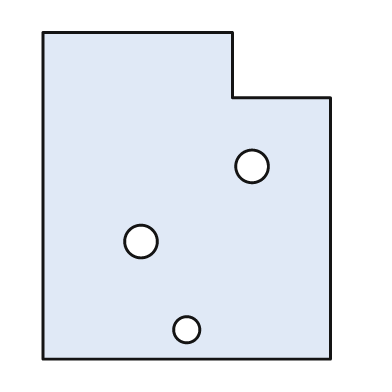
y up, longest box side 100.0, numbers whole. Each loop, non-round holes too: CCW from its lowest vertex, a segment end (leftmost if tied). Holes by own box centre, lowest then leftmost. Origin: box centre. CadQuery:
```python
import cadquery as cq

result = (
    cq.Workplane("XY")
    .moveTo(-44.0, -50.0)
    .lineTo(44.0, -50.0)
    .lineTo(44.0, 30.0)
    .lineTo(14.0, 30.0)
    .lineTo(14.0, 50.0)
    .lineTo(-44.0, 50.0)
    .close()
    .moveTo(0.0, -41.0)
    .circle(4.0)
    .moveTo(-14.0, -14.0)
    .circle(5.0)
    .moveTo(20.0, 9.0)
    .circle(5.0)
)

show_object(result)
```